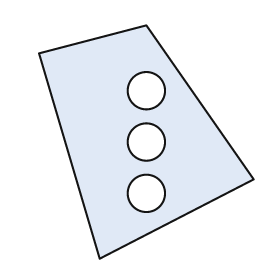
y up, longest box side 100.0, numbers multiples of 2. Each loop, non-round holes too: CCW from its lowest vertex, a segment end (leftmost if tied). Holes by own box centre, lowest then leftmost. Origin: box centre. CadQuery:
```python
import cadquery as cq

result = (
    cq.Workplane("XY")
    .moveTo(-20.0, -50.0)
    .lineTo(46.0, -16.0)
    .lineTo(0.0, 50.0)
    .lineTo(-46.0, 38.0)
    .close()
    .moveTo(0.0, -22.0)
    .circle(8.0)
    .moveTo(0.0, 0.0)
    .circle(8.0)
    .moveTo(0.0, 22.0)
    .circle(8.0)
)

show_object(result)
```